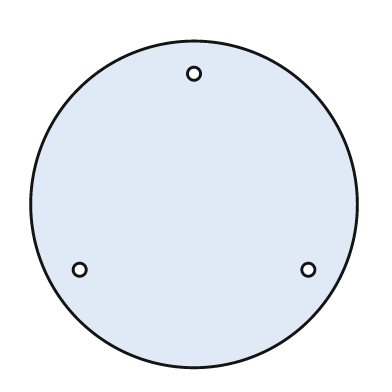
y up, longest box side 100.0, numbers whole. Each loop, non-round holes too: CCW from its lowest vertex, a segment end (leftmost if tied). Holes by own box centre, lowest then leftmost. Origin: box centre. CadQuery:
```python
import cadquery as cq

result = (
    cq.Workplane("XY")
    .moveTo(0.0, 0.0)
    .circle(50.0)
    .moveTo(-35.0, -20.0)
    .circle(2.0)
    .moveTo(35.0, -20.0)
    .circle(2.0)
    .moveTo(0.0, 40.0)
    .circle(2.0)
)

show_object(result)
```